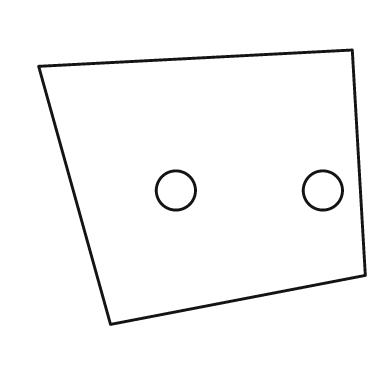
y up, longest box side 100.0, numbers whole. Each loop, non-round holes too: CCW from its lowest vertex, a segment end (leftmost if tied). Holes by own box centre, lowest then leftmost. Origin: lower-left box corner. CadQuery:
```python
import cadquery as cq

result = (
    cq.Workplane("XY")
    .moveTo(22.0, 0.0)
    .lineTo(100.0, 15.0)
    .lineTo(96.0, 84.0)
    .lineTo(0.0, 79.0)
    .close()
    .moveTo(42.0, 41.0)
    .circle(6.0)
    .moveTo(87.0, 41.0)
    .circle(6.0)
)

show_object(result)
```